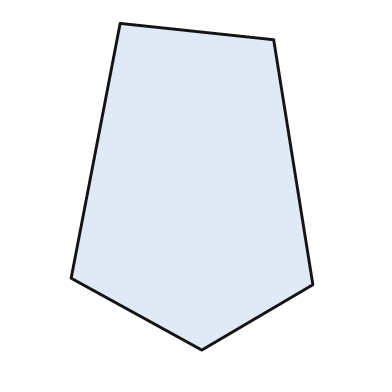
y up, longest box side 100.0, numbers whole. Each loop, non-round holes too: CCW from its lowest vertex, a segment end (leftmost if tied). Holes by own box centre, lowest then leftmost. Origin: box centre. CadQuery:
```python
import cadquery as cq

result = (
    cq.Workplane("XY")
    .moveTo(3.0, -50.0)
    .lineTo(37.0, -30.0)
    .lineTo(25.0, 45.0)
    .lineTo(-22.0, 50.0)
    .lineTo(-37.0, -28.0)
    .close()
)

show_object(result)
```